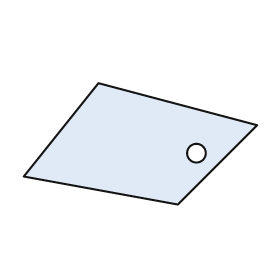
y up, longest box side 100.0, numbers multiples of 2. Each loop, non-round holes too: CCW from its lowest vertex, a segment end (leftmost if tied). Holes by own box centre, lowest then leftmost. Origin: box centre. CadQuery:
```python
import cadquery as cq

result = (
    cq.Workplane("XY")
    .moveTo(16.0, -26.0)
    .lineTo(50.0, 8.0)
    .lineTo(-18.0, 26.0)
    .lineTo(-50.0, -14.0)
    .close()
    .moveTo(24.0, -4.0)
    .circle(4.0)
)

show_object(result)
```